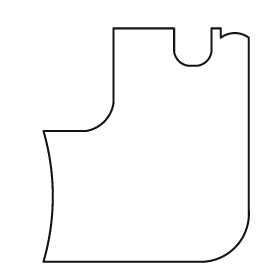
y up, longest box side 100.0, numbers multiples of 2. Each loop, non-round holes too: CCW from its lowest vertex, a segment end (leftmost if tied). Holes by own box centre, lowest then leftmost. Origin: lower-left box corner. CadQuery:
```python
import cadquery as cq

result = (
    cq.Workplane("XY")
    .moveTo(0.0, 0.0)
    .lineTo(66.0, 0.0)
    .threePointArc((82.0, 6.0), (88.0, 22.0))
    .lineTo(88.0, 96.0)
    .threePointArc((82.0, 98.0), (76.0, 96.0))
    .lineTo(76.0, 100.0)
    .lineTo(72.0, 100.0)
    .lineTo(72.0, 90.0)
    .threePointArc((70.0, 86.0), (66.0, 84.0))
    .lineTo(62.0, 84.0)
    .threePointArc((58.0, 86.0), (56.0, 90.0))
    .lineTo(56.0, 100.0)
    .lineTo(30.0, 100.0)
    .lineTo(30.0, 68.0)
    .threePointArc((26.0, 60.0), (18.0, 56.0))
    .lineTo(0.0, 56.0)
    .threePointArc((4.0, 28.0), (0.0, 0.0))
    .close()
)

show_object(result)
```